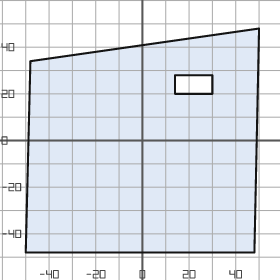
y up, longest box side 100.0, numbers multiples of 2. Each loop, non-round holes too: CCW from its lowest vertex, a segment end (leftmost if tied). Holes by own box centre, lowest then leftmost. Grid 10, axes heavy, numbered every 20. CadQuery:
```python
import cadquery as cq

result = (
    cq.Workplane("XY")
    .moveTo(-50.0, -48.0)
    .lineTo(48.0, -48.0)
    .lineTo(50.0, 48.0)
    .lineTo(-48.0, 34.0)
    .close()
    .moveTo(14.0, 20.0)
    .lineTo(30.0, 20.0)
    .lineTo(30.0, 28.0)
    .lineTo(14.0, 28.0)
    .close()
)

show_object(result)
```